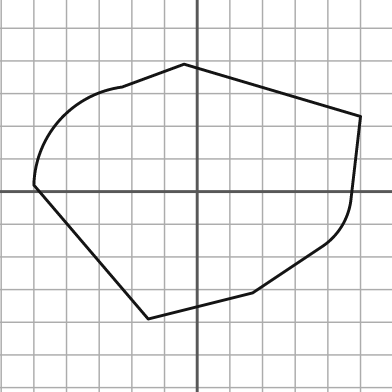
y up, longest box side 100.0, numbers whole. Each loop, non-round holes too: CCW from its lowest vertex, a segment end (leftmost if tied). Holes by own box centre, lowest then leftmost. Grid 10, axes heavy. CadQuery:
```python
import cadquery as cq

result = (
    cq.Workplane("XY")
    .moveTo(-15.0, -39.0)
    .lineTo(17.0, -31.0)
    .lineTo(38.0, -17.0)
    .threePointArc((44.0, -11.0), (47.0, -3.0))
    .lineTo(50.0, 23.0)
    .lineTo(-4.0, 39.0)
    .lineTo(-23.0, 32.0)
    .threePointArc((-42.0, 22.0), (-50.0, 2.0))
    .close()
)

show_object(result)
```